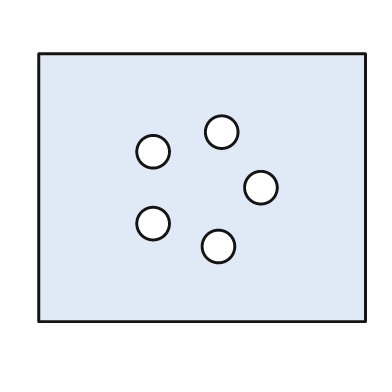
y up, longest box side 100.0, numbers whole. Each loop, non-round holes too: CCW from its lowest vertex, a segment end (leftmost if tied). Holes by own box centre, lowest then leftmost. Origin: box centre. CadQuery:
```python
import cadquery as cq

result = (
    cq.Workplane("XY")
    .moveTo(-50.0, -41.0)
    .lineTo(50.0, -41.0)
    .lineTo(50.0, 41.0)
    .lineTo(-50.0, 41.0)
    .close()
    .moveTo(5.0, -18.0)
    .circle(5.0)
    .moveTo(-15.0, -11.0)
    .circle(5.0)
    .moveTo(18.0, 0.0)
    .circle(5.0)
    .moveTo(-15.0, 11.0)
    .circle(5.0)
    .moveTo(6.0, 17.0)
    .circle(5.0)
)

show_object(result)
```